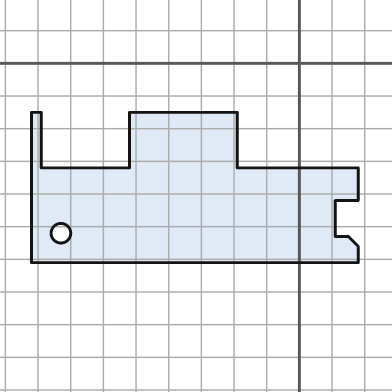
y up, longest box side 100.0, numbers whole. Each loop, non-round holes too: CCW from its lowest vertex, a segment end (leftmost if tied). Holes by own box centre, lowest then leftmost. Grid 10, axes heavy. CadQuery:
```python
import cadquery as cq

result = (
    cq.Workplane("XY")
    .moveTo(-82.0, -61.0)
    .lineTo(18.0, -61.0)
    .lineTo(18.0, -56.0)
    .lineTo(15.0, -53.0)
    .lineTo(11.0, -53.0)
    .lineTo(11.0, -42.0)
    .lineTo(18.0, -42.0)
    .lineTo(18.0, -32.0)
    .lineTo(-19.0, -32.0)
    .lineTo(-19.0, -15.0)
    .lineTo(-52.0, -15.0)
    .lineTo(-52.0, -32.0)
    .lineTo(-79.0, -32.0)
    .lineTo(-79.0, -15.0)
    .lineTo(-82.0, -15.0)
    .close()
    .moveTo(-73.0, -52.0)
    .circle(3.0)
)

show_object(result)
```